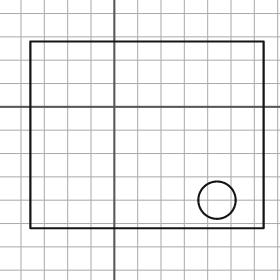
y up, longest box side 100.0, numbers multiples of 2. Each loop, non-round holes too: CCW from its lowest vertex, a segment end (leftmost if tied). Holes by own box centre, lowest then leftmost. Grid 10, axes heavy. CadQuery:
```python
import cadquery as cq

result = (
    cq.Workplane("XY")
    .moveTo(-36.0, -52.0)
    .lineTo(64.0, -52.0)
    .lineTo(64.0, 28.0)
    .lineTo(-36.0, 28.0)
    .close()
    .moveTo(44.0, -40.0)
    .circle(8.0)
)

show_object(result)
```